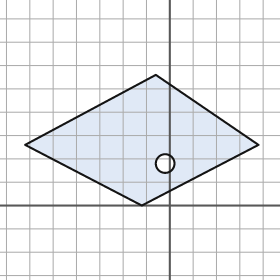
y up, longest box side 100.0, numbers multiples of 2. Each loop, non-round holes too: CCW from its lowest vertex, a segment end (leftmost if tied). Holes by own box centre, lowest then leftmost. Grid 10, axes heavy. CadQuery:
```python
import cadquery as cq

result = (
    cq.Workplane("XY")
    .moveTo(-12.0, 0.0)
    .lineTo(38.0, 26.0)
    .lineTo(-6.0, 56.0)
    .lineTo(-62.0, 26.0)
    .close()
    .moveTo(-2.0, 18.0)
    .circle(4.0)
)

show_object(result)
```